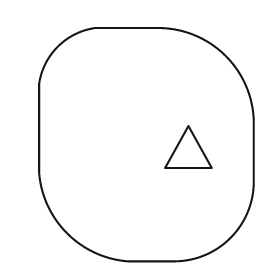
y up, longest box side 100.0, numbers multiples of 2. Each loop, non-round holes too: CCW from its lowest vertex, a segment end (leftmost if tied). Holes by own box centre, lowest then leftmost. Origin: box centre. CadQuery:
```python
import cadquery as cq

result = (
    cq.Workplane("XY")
    .moveTo(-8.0, -50.0)
    .lineTo(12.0, -50.0)
    .threePointArc((36.0, -40.0), (46.0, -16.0))
    .lineTo(46.0, 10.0)
    .threePointArc((34.0, 38.0), (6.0, 50.0))
    .lineTo(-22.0, 50.0)
    .threePointArc((-38.0, 42.0), (-46.0, 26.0))
    .lineTo(-46.0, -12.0)
    .threePointArc((-34.0, -38.0), (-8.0, -50.0))
    .close()
    .moveTo(8.0, -10.0)
    .lineTo(28.0, -10.0)
    .lineTo(18.0, 8.0)
    .close()
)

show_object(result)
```